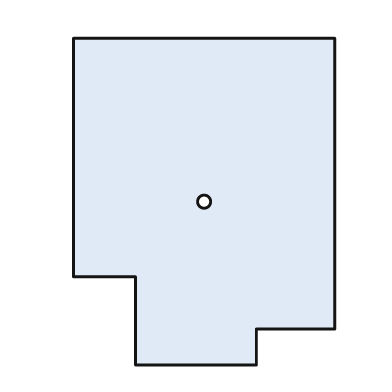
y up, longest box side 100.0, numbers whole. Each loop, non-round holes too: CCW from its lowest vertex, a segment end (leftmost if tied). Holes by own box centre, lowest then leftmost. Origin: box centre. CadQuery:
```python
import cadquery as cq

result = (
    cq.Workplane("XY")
    .moveTo(-21.0, -50.0)
    .lineTo(16.0, -50.0)
    .lineTo(16.0, -39.0)
    .lineTo(40.0, -39.0)
    .lineTo(40.0, 50.0)
    .lineTo(-40.0, 50.0)
    .lineTo(-40.0, -23.0)
    .lineTo(-21.0, -23.0)
    .close()
    .moveTo(0.0, 0.0)
    .circle(2.0)
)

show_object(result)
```